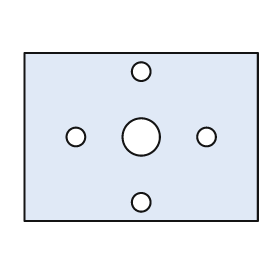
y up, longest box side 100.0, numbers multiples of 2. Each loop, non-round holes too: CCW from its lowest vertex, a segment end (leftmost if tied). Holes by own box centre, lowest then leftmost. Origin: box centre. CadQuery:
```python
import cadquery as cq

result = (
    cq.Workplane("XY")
    .moveTo(-50.0, -36.0)
    .lineTo(50.0, -36.0)
    .lineTo(50.0, 36.0)
    .lineTo(-50.0, 36.0)
    .close()
    .moveTo(0.0, -28.0)
    .circle(4.0)
    .moveTo(-28.0, 0.0)
    .circle(4.0)
    .moveTo(0.0, 0.0)
    .circle(8.0)
    .moveTo(28.0, 0.0)
    .circle(4.0)
    .moveTo(0.0, 28.0)
    .circle(4.0)
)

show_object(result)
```